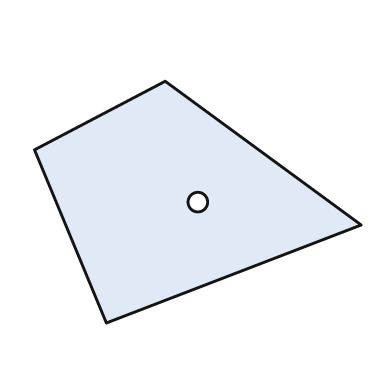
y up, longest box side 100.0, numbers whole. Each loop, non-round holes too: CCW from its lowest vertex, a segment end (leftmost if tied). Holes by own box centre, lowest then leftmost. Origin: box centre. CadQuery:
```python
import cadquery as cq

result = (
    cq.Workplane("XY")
    .moveTo(-28.0, -37.0)
    .lineTo(50.0, -7.0)
    .lineTo(-10.0, 37.0)
    .lineTo(-50.0, 16.0)
    .close()
    .moveTo(0.0, 0.0)
    .circle(3.0)
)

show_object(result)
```